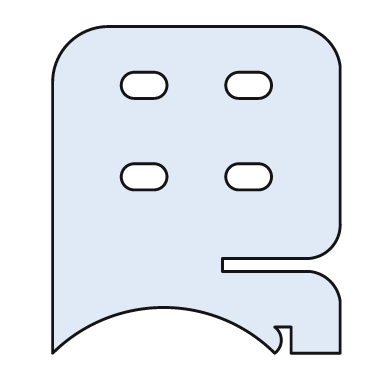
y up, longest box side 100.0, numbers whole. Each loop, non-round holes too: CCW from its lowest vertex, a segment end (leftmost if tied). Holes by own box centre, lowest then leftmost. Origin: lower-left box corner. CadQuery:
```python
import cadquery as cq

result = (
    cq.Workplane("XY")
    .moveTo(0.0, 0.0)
    .threePointArc((34.0, 14.0), (68.0, 0.0))
    .threePointArc((70.0, 4.0), (68.0, 8.0))
    .lineTo(73.0, 8.0)
    .lineTo(73.0, 0.0)
    .lineTo(88.0, 0.0)
    .lineTo(88.0, 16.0)
    .threePointArc((85.0, 22.0), (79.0, 25.0))
    .lineTo(52.0, 25.0)
    .lineTo(52.0, 29.0)
    .lineTo(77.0, 29.0)
    .threePointArc((85.0, 32.0), (88.0, 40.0))
    .lineTo(88.0, 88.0)
    .threePointArc((84.0, 96.0), (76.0, 100.0))
    .lineTo(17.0, 100.0)
    .threePointArc((5.0, 95.0), (0.0, 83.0))
    .close()
    .moveTo(25.0, 50.0)
    .lineTo(31.0, 50.0)
    .threePointArc((35.0, 54.0), (31.0, 58.0))
    .lineTo(25.0, 58.0)
    .threePointArc((21.0, 54.0), (25.0, 50.0))
    .close()
    .moveTo(57.0, 50.0)
    .lineTo(63.0, 50.0)
    .threePointArc((67.0, 54.0), (63.0, 58.0))
    .lineTo(57.0, 58.0)
    .threePointArc((53.0, 54.0), (57.0, 50.0))
    .close()
    .moveTo(25.0, 78.0)
    .lineTo(31.0, 78.0)
    .threePointArc((35.0, 82.0), (31.0, 86.0))
    .lineTo(25.0, 86.0)
    .threePointArc((21.0, 82.0), (25.0, 78.0))
    .close()
    .moveTo(57.0, 78.0)
    .lineTo(63.0, 78.0)
    .threePointArc((67.0, 82.0), (63.0, 86.0))
    .lineTo(57.0, 86.0)
    .threePointArc((53.0, 82.0), (57.0, 78.0))
    .close()
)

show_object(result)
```